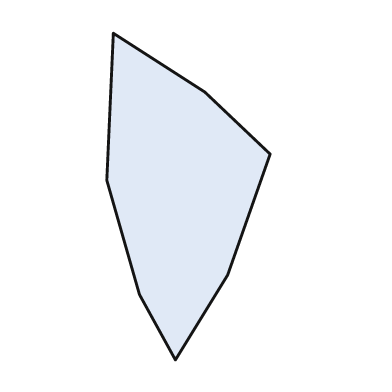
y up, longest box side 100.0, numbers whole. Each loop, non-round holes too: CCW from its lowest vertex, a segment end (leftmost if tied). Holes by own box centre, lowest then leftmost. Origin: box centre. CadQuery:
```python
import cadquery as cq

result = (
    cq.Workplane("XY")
    .moveTo(-4.0, -50.0)
    .lineTo(12.0, -24.0)
    .lineTo(25.0, 13.0)
    .lineTo(5.0, 32.0)
    .lineTo(-23.0, 50.0)
    .lineTo(-25.0, 5.0)
    .lineTo(-15.0, -30.0)
    .close()
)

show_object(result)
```